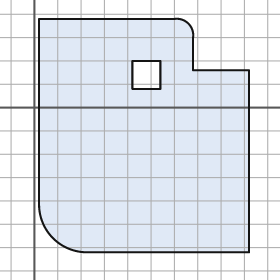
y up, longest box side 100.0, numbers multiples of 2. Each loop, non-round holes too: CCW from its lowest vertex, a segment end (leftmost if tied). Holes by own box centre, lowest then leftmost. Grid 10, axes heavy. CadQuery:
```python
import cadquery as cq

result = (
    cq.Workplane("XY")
    .moveTo(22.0, -62.0)
    .lineTo(92.0, -62.0)
    .lineTo(92.0, 16.0)
    .lineTo(68.0, 16.0)
    .lineTo(68.0, 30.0)
    .threePointArc((66.0, 36.0), (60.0, 38.0))
    .lineTo(2.0, 38.0)
    .lineTo(2.0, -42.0)
    .threePointArc((8.0, -56.0), (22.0, -62.0))
    .close()
    .moveTo(42.0, 8.0)
    .lineTo(54.0, 8.0)
    .lineTo(54.0, 20.0)
    .lineTo(42.0, 20.0)
    .close()
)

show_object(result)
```